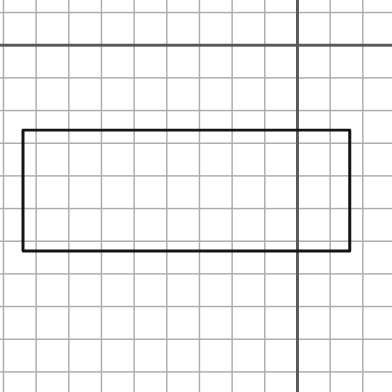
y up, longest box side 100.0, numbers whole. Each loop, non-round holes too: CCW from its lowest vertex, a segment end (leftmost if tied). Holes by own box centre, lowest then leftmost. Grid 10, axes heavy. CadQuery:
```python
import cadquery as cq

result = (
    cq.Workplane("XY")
    .moveTo(-84.0, -63.0)
    .lineTo(16.0, -63.0)
    .lineTo(16.0, -26.0)
    .lineTo(-84.0, -26.0)
    .close()
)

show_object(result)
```